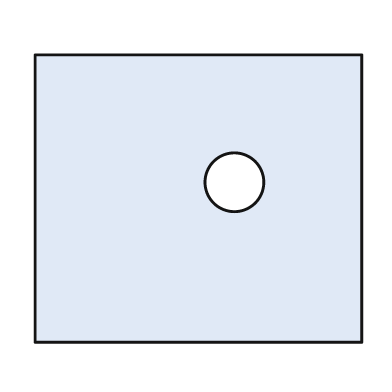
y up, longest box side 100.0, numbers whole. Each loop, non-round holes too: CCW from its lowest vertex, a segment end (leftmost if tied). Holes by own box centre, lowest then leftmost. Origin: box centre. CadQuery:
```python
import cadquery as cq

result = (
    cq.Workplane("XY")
    .moveTo(-50.0, -44.0)
    .lineTo(50.0, -44.0)
    .lineTo(50.0, 44.0)
    .lineTo(-50.0, 44.0)
    .close()
    .moveTo(11.0, 5.0)
    .circle(9.0)
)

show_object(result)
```